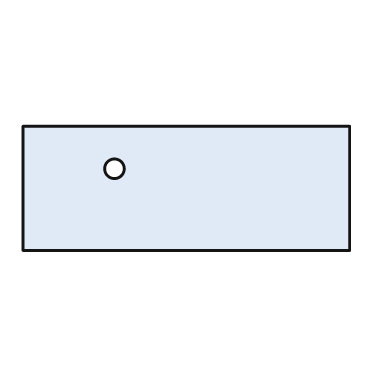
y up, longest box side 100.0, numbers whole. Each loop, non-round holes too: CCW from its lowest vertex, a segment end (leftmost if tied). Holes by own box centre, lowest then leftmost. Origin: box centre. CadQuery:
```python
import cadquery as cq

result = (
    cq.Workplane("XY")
    .moveTo(-50.0, -19.0)
    .lineTo(50.0, -19.0)
    .lineTo(50.0, 19.0)
    .lineTo(-50.0, 19.0)
    .close()
    .moveTo(-22.0, 6.0)
    .circle(3.0)
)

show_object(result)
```